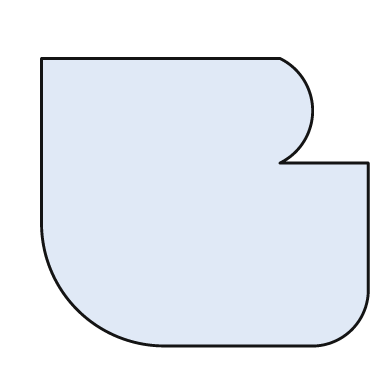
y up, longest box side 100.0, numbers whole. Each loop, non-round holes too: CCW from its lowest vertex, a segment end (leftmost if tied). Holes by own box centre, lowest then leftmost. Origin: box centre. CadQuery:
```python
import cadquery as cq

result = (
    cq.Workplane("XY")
    .moveTo(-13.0, -44.0)
    .lineTo(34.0, -44.0)
    .threePointArc((45.0, -39.0), (50.0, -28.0))
    .lineTo(50.0, 12.0)
    .lineTo(23.0, 12.0)
    .threePointArc((33.0, 28.0), (23.0, 44.0))
    .lineTo(-50.0, 44.0)
    .lineTo(-50.0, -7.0)
    .threePointArc((-39.0, -33.0), (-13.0, -44.0))
    .close()
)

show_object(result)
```